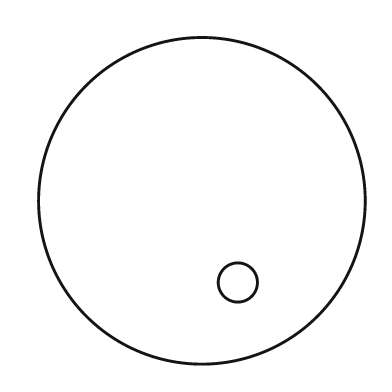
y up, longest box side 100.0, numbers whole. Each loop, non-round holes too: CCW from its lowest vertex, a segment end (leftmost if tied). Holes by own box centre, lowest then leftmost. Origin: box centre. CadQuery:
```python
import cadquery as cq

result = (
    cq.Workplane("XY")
    .moveTo(0.0, 0.0)
    .circle(50.0)
    .moveTo(11.0, -25.0)
    .circle(6.0)
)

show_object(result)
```